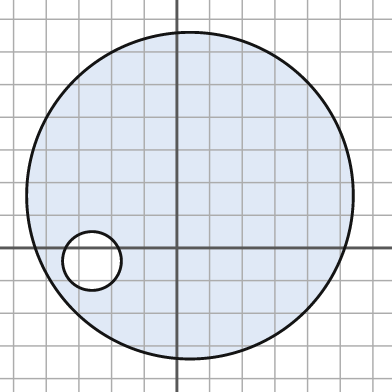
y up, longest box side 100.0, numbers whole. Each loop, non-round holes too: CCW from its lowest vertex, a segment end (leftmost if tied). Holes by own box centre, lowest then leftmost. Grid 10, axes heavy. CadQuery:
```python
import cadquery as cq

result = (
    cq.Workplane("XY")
    .moveTo(4.0, 16.0)
    .circle(50.0)
    .moveTo(-26.0, -4.0)
    .circle(9.0)
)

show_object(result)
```